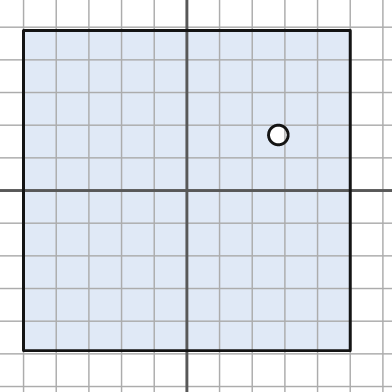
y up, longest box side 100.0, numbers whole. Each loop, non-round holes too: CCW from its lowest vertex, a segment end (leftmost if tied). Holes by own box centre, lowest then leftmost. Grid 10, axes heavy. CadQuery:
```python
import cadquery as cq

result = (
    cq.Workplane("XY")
    .moveTo(-50.0, -49.0)
    .lineTo(50.0, -49.0)
    .lineTo(50.0, 49.0)
    .lineTo(-50.0, 49.0)
    .close()
    .moveTo(28.0, 17.0)
    .circle(3.0)
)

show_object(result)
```